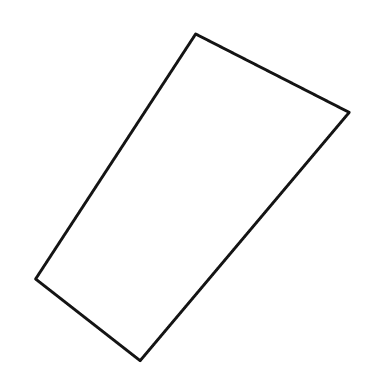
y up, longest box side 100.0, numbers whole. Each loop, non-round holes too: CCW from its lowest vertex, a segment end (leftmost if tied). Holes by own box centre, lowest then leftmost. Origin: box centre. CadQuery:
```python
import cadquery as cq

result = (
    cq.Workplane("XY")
    .moveTo(-16.0, -50.0)
    .lineTo(48.0, 26.0)
    .lineTo(1.0, 50.0)
    .lineTo(-48.0, -25.0)
    .close()
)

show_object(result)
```